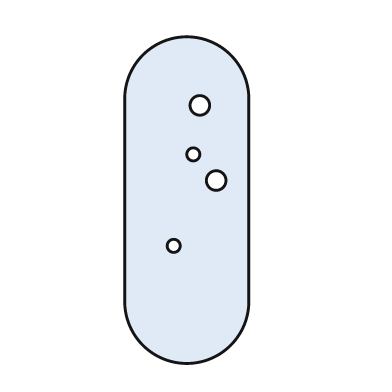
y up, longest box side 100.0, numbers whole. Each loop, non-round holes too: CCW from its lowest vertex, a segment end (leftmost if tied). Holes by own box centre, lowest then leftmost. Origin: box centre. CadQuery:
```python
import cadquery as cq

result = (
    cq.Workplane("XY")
    .moveTo(-19.0, -31.0)
    .threePointArc((0.0, -50.0), (19.0, -31.0))
    .lineTo(19.0, 31.0)
    .threePointArc((0.0, 50.0), (-19.0, 31.0))
    .close()
    .moveTo(-4.0, -14.0)
    .circle(2.0)
    .moveTo(9.0, 6.0)
    .circle(3.0)
    .moveTo(2.0, 14.0)
    .circle(2.0)
    .moveTo(4.0, 29.0)
    .circle(3.0)
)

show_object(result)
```